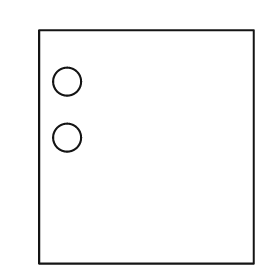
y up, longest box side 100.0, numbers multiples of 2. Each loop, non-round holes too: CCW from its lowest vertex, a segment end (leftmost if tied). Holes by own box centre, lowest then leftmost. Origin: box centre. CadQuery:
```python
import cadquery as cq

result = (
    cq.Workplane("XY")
    .moveTo(-46.0, -50.0)
    .lineTo(46.0, -50.0)
    .lineTo(46.0, 50.0)
    .lineTo(-46.0, 50.0)
    .close()
    .moveTo(-34.0, 4.0)
    .circle(6.0)
    .moveTo(-34.0, 28.0)
    .circle(6.0)
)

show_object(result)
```